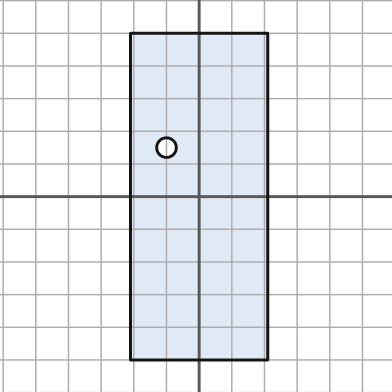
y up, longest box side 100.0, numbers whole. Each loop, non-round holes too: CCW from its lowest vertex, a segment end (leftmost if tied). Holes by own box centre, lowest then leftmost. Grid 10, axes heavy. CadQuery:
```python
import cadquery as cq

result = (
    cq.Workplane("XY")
    .moveTo(-21.0, -50.0)
    .lineTo(21.0, -50.0)
    .lineTo(21.0, 50.0)
    .lineTo(-21.0, 50.0)
    .close()
    .moveTo(-10.0, 15.0)
    .circle(3.0)
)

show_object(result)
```